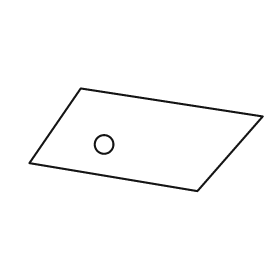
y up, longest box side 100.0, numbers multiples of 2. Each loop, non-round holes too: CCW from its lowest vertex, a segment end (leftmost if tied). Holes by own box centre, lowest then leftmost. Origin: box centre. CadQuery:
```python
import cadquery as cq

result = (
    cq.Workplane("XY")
    .moveTo(22.0, -22.0)
    .lineTo(50.0, 10.0)
    .lineTo(-28.0, 22.0)
    .lineTo(-50.0, -10.0)
    .close()
    .moveTo(-18.0, -2.0)
    .circle(4.0)
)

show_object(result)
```